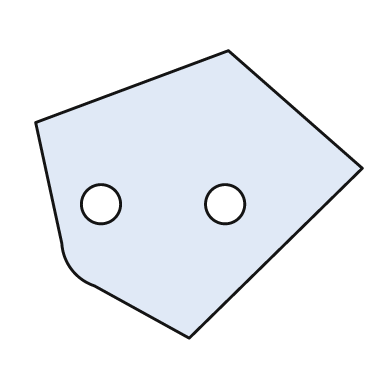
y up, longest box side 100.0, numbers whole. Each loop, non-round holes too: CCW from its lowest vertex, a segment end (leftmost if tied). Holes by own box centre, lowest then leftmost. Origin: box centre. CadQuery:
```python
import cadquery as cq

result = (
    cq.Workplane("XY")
    .moveTo(-3.0, -44.0)
    .lineTo(50.0, 8.0)
    .lineTo(9.0, 44.0)
    .lineTo(-50.0, 22.0)
    .lineTo(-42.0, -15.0)
    .threePointArc((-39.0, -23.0), (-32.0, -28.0))
    .close()
    .moveTo(-30.0, -3.0)
    .circle(6.0)
    .moveTo(8.0, -3.0)
    .circle(6.0)
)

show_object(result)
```